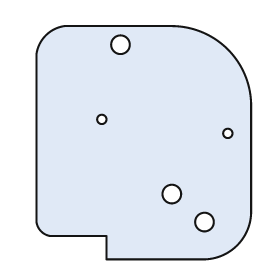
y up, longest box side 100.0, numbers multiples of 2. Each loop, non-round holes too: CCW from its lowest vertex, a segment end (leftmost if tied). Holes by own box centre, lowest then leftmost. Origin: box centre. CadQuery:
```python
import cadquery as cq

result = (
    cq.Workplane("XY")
    .moveTo(-16.0, -50.0)
    .lineTo(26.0, -50.0)
    .threePointArc((40.0, -44.0), (46.0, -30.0))
    .lineTo(46.0, 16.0)
    .threePointArc((36.0, 40.0), (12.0, 50.0))
    .lineTo(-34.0, 50.0)
    .threePointArc((-42.0, 46.0), (-46.0, 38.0))
    .lineTo(-46.0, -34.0)
    .threePointArc((-44.0, -38.0), (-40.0, -40.0))
    .lineTo(-16.0, -40.0)
    .close()
    .moveTo(26.0, -34.0)
    .circle(4.0)
    .moveTo(12.0, -22.0)
    .circle(4.0)
    .moveTo(36.0, 4.0)
    .circle(2.0)
    .moveTo(-18.0, 10.0)
    .circle(2.0)
    .moveTo(-10.0, 42.0)
    .circle(4.0)
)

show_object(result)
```